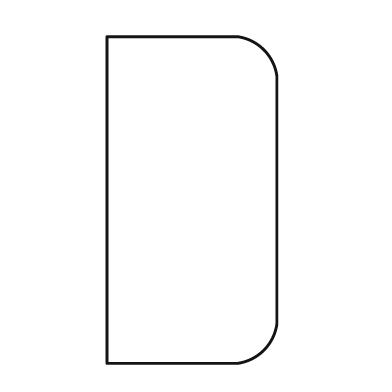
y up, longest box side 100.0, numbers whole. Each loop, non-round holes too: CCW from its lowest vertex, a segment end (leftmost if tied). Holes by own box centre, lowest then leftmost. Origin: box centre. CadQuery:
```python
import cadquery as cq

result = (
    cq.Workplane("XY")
    .moveTo(-26.0, -50.0)
    .lineTo(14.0, -50.0)
    .threePointArc((22.0, -46.0), (26.0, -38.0))
    .lineTo(26.0, 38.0)
    .threePointArc((22.0, 46.0), (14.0, 50.0))
    .lineTo(-26.0, 50.0)
    .close()
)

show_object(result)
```